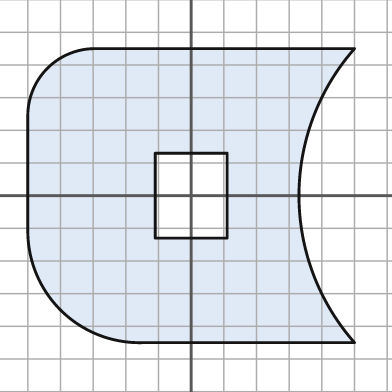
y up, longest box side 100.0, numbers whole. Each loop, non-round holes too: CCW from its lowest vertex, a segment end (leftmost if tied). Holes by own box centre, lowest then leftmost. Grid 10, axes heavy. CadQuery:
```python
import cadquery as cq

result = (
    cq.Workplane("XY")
    .moveTo(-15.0, -45.0)
    .lineTo(50.0, -45.0)
    .threePointArc((33.0, 0.0), (50.0, 45.0))
    .lineTo(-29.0, 45.0)
    .threePointArc((-44.0, 39.0), (-50.0, 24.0))
    .lineTo(-50.0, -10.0)
    .threePointArc((-40.0, -35.0), (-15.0, -45.0))
    .close()
    .moveTo(-11.0, -13.0)
    .lineTo(11.0, -13.0)
    .lineTo(11.0, 13.0)
    .lineTo(-11.0, 13.0)
    .close()
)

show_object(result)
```